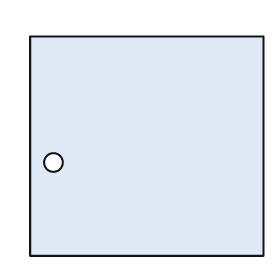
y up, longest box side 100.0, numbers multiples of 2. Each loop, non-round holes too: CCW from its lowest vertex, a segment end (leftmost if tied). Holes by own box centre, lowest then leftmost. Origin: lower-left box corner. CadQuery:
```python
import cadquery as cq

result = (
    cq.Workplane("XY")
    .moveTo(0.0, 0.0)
    .lineTo(100.0, 0.0)
    .lineTo(100.0, 94.0)
    .lineTo(0.0, 94.0)
    .close()
    .moveTo(10.0, 40.0)
    .circle(4.0)
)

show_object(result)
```